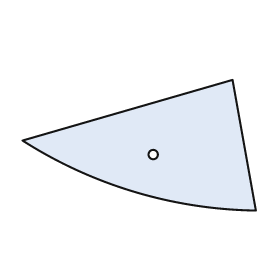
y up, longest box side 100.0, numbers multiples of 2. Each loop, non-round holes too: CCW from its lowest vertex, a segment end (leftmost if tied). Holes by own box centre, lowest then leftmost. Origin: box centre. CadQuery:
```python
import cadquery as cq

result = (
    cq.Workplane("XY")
    .moveTo(50.0, -28.0)
    .lineTo(40.0, 28.0)
    .lineTo(-50.0, 2.0)
    .threePointArc((-2.0, -20.0), (50.0, -28.0))
    .close()
    .moveTo(6.0, -4.0)
    .circle(2.0)
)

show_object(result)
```